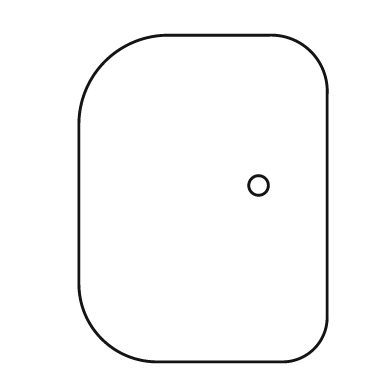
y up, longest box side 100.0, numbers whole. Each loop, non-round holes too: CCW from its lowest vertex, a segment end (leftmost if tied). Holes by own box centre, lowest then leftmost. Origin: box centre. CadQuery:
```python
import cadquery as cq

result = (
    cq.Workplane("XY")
    .moveTo(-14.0, -50.0)
    .lineTo(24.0, -50.0)
    .threePointArc((34.0, -46.0), (38.0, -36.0))
    .lineTo(38.0, 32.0)
    .threePointArc((33.0, 45.0), (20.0, 50.0))
    .lineTo(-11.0, 50.0)
    .threePointArc((-30.0, 42.0), (-38.0, 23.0))
    .lineTo(-38.0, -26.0)
    .threePointArc((-31.0, -43.0), (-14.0, -50.0))
    .close()
    .moveTo(17.0, 4.0)
    .circle(3.0)
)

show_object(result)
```